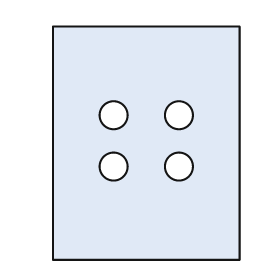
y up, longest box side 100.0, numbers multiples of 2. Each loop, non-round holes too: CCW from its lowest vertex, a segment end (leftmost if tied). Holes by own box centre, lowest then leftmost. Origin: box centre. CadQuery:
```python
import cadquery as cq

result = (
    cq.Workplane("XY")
    .moveTo(-40.0, -50.0)
    .lineTo(40.0, -50.0)
    .lineTo(40.0, 50.0)
    .lineTo(-40.0, 50.0)
    .close()
    .moveTo(-14.0, -10.0)
    .circle(6.0)
    .moveTo(14.0, -10.0)
    .circle(6.0)
    .moveTo(-14.0, 12.0)
    .circle(6.0)
    .moveTo(14.0, 12.0)
    .circle(6.0)
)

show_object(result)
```